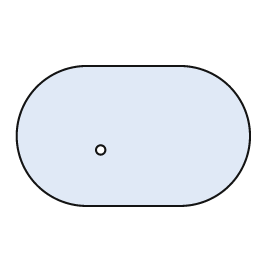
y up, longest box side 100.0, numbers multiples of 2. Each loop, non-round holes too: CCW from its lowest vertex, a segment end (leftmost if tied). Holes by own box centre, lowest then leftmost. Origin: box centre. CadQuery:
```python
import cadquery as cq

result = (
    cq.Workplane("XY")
    .moveTo(-20.0, -30.0)
    .lineTo(20.0, -30.0)
    .threePointArc((50.0, 0.0), (20.0, 30.0))
    .lineTo(-20.0, 30.0)
    .threePointArc((-50.0, 0.0), (-20.0, -30.0))
    .close()
    .moveTo(-14.0, -6.0)
    .circle(2.0)
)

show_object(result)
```